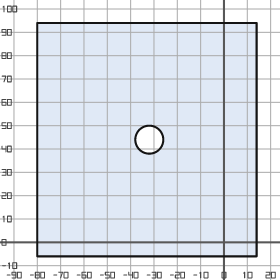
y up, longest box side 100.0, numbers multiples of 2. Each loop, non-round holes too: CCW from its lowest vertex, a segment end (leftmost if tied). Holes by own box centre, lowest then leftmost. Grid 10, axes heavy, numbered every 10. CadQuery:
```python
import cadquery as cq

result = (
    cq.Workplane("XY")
    .moveTo(-80.0, -6.0)
    .lineTo(14.0, -6.0)
    .lineTo(14.0, 94.0)
    .lineTo(-80.0, 94.0)
    .close()
    .moveTo(-32.0, 44.0)
    .circle(6.0)
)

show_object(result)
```